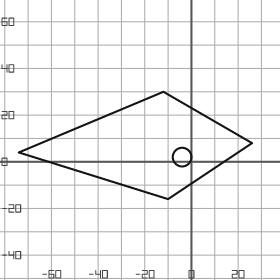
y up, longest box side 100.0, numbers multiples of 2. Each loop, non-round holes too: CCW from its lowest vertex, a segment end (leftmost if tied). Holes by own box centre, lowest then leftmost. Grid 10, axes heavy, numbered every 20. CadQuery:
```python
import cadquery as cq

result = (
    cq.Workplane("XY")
    .moveTo(-10.0, -16.0)
    .lineTo(26.0, 8.0)
    .lineTo(-12.0, 30.0)
    .lineTo(-74.0, 4.0)
    .close()
    .moveTo(-4.0, 2.0)
    .circle(4.0)
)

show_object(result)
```